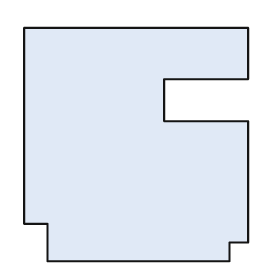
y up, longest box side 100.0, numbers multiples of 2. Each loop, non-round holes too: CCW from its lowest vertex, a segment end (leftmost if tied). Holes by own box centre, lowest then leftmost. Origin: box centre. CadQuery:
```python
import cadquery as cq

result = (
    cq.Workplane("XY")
    .moveTo(-38.0, -50.0)
    .lineTo(40.0, -50.0)
    .lineTo(40.0, -42.0)
    .lineTo(48.0, -42.0)
    .lineTo(48.0, 10.0)
    .lineTo(12.0, 10.0)
    .lineTo(12.0, 28.0)
    .lineTo(48.0, 28.0)
    .lineTo(48.0, 50.0)
    .lineTo(-48.0, 50.0)
    .lineTo(-48.0, -34.0)
    .lineTo(-38.0, -34.0)
    .close()
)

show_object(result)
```